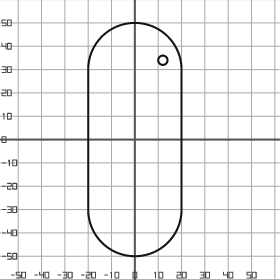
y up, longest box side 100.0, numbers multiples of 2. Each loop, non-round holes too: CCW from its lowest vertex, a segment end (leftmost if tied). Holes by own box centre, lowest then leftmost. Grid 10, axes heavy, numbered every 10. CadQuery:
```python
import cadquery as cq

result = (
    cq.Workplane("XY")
    .moveTo(-20.0, -30.0)
    .threePointArc((0.0, -50.0), (20.0, -30.0))
    .lineTo(20.0, 30.0)
    .threePointArc((0.0, 50.0), (-20.0, 30.0))
    .close()
    .moveTo(12.0, 34.0)
    .circle(2.0)
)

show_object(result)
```